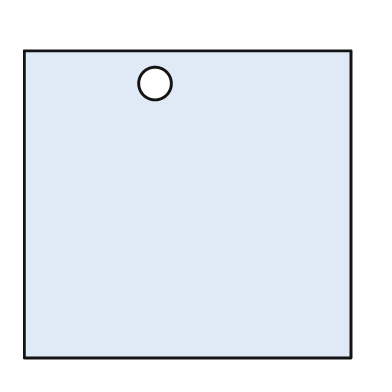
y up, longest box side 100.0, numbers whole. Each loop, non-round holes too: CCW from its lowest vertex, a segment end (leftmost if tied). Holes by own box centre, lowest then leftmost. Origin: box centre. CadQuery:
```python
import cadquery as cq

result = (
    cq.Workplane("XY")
    .moveTo(-50.0, -47.0)
    .lineTo(50.0, -47.0)
    .lineTo(50.0, 47.0)
    .lineTo(-50.0, 47.0)
    .close()
    .moveTo(-10.0, 37.0)
    .circle(5.0)
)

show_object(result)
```